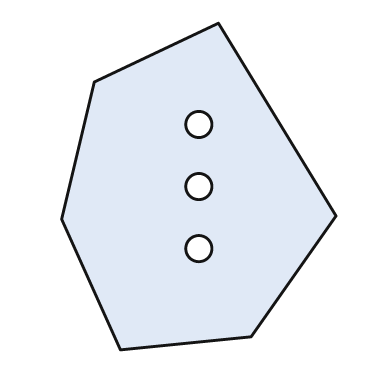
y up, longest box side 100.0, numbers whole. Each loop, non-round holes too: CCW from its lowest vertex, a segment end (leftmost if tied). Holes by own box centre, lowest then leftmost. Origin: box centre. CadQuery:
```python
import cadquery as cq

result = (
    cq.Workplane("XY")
    .moveTo(-24.0, -50.0)
    .lineTo(16.0, -46.0)
    .lineTo(42.0, -9.0)
    .lineTo(6.0, 50.0)
    .lineTo(-32.0, 32.0)
    .lineTo(-42.0, -10.0)
    .close()
    .moveTo(0.0, -19.0)
    .circle(4.0)
    .moveTo(0.0, 0.0)
    .circle(4.0)
    .moveTo(0.0, 19.0)
    .circle(4.0)
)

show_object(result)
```